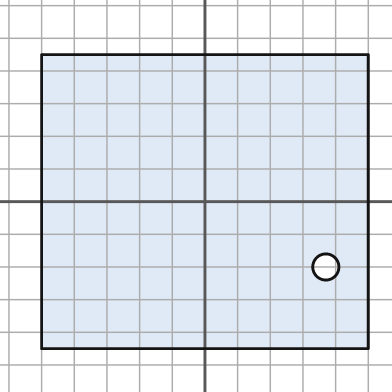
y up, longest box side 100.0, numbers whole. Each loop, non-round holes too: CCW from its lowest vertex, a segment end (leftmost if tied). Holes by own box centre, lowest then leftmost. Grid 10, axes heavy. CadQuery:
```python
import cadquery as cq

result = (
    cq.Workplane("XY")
    .moveTo(-50.0, -45.0)
    .lineTo(50.0, -45.0)
    .lineTo(50.0, 45.0)
    .lineTo(-50.0, 45.0)
    .close()
    .moveTo(37.0, -20.0)
    .circle(4.0)
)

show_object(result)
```